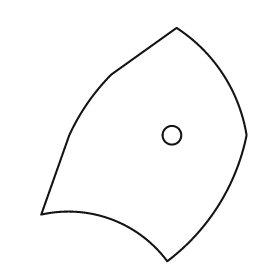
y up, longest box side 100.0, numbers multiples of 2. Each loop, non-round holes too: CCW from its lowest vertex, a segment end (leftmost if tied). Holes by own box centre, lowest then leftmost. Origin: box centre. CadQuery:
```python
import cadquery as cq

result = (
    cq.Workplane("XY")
    .moveTo(10.0, -50.0)
    .threePointArc((32.0, -26.0), (44.0, 4.0))
    .threePointArc((34.0, 30.0), (14.0, 50.0))
    .lineTo(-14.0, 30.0)
    .threePointArc((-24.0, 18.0), (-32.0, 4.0))
    .lineTo(-44.0, -30.0)
    .threePointArc((-14.0, -32.0), (10.0, -50.0))
    .close()
    .moveTo(12.0, 4.0)
    .circle(4.0)
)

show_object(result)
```